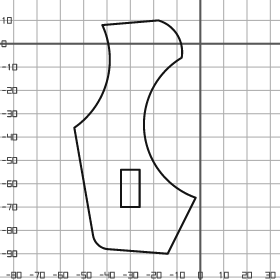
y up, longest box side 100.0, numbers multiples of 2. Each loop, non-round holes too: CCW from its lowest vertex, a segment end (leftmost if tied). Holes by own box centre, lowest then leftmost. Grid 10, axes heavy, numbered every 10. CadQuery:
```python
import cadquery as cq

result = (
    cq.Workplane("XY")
    .moveTo(-14.0, -90.0)
    .lineTo(-2.0, -66.0)
    .threePointArc((-24.0, -38.0), (-8.0, -6.0))
    .threePointArc((-10.0, 4.0), (-18.0, 10.0))
    .lineTo(-42.0, 8.0)
    .threePointArc((-40.0, -16.0), (-54.0, -36.0))
    .lineTo(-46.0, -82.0)
    .threePointArc((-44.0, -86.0), (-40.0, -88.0))
    .close()
    .moveTo(-34.0, -70.0)
    .lineTo(-26.0, -70.0)
    .lineTo(-26.0, -54.0)
    .lineTo(-34.0, -54.0)
    .close()
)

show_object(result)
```